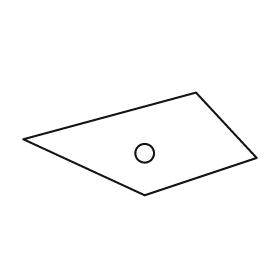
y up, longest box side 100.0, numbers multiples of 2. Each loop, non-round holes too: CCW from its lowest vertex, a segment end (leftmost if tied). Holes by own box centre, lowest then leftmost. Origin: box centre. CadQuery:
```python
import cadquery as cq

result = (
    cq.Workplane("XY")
    .moveTo(2.0, -22.0)
    .lineTo(50.0, -6.0)
    .lineTo(24.0, 22.0)
    .lineTo(-50.0, 2.0)
    .close()
    .moveTo(2.0, -4.0)
    .circle(4.0)
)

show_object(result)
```